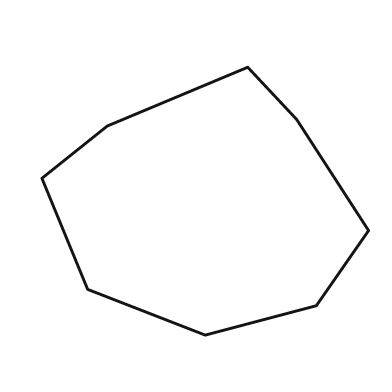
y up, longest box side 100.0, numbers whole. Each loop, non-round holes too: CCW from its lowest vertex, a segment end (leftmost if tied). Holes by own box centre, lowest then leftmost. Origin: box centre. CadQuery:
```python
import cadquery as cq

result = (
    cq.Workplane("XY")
    .moveTo(0.0, -41.0)
    .lineTo(34.0, -32.0)
    .lineTo(50.0, -9.0)
    .lineTo(28.0, 25.0)
    .lineTo(13.0, 41.0)
    .lineTo(-30.0, 23.0)
    .lineTo(-50.0, 7.0)
    .lineTo(-36.0, -27.0)
    .close()
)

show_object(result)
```